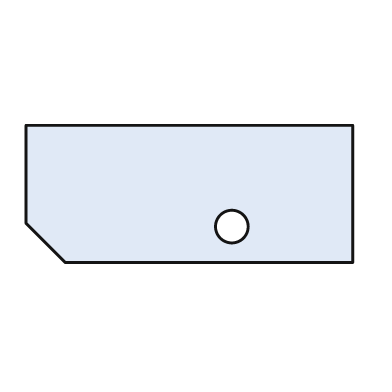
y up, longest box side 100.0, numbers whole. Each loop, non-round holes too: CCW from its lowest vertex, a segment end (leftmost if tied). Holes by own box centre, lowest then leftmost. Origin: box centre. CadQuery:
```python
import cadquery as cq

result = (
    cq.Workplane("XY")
    .moveTo(-38.0, -21.0)
    .lineTo(50.0, -21.0)
    .lineTo(50.0, 21.0)
    .lineTo(-50.0, 21.0)
    .lineTo(-50.0, -9.0)
    .close()
    .moveTo(13.0, -10.0)
    .circle(5.0)
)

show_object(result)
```